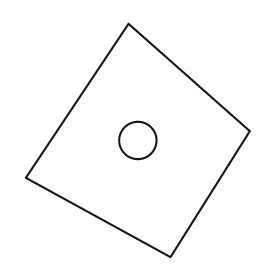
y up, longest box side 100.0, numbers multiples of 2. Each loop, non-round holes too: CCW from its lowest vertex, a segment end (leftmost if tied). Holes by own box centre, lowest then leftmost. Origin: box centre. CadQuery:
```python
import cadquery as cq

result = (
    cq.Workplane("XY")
    .moveTo(14.0, -50.0)
    .lineTo(48.0, 4.0)
    .lineTo(-4.0, 50.0)
    .lineTo(-48.0, -16.0)
    .close()
    .moveTo(0.0, 0.0)
    .circle(8.0)
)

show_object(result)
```